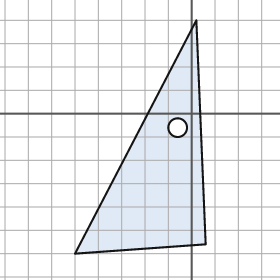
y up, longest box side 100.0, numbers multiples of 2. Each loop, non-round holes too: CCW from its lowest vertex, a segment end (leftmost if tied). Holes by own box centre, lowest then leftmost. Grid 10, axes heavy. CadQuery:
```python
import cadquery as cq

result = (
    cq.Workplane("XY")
    .moveTo(-50.0, -60.0)
    .lineTo(6.0, -56.0)
    .lineTo(2.0, 40.0)
    .close()
    .moveTo(-6.0, -6.0)
    .circle(4.0)
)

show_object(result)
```